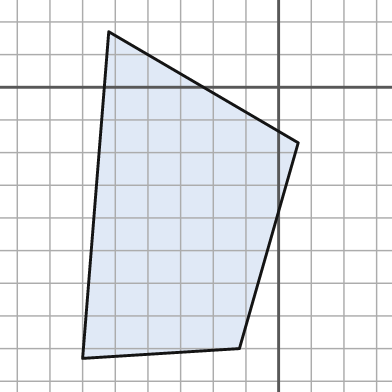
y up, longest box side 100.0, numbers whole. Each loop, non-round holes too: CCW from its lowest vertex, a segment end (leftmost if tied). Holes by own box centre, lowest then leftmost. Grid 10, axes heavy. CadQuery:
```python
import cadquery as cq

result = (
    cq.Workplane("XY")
    .moveTo(-60.0, -83.0)
    .lineTo(-12.0, -80.0)
    .lineTo(6.0, -17.0)
    .lineTo(-52.0, 17.0)
    .close()
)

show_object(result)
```